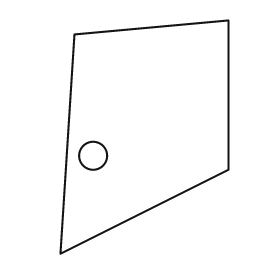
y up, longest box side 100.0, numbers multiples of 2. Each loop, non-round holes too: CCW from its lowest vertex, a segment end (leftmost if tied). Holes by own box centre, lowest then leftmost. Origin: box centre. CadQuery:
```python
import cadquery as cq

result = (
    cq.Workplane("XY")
    .moveTo(-36.0, -50.0)
    .lineTo(36.0, -14.0)
    .lineTo(36.0, 50.0)
    .lineTo(-30.0, 44.0)
    .close()
    .moveTo(-22.0, -8.0)
    .circle(6.0)
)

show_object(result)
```